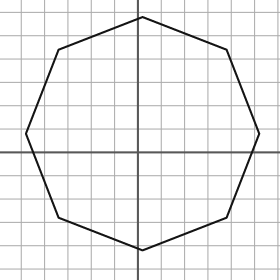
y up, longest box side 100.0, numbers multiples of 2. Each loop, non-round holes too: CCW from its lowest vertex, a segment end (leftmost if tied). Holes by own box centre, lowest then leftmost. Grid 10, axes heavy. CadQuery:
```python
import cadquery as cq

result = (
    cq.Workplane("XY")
    .moveTo(2.0, -42.0)
    .lineTo(38.0, -28.0)
    .lineTo(52.0, 8.0)
    .lineTo(38.0, 44.0)
    .lineTo(2.0, 58.0)
    .lineTo(-34.0, 44.0)
    .lineTo(-48.0, 8.0)
    .lineTo(-34.0, -28.0)
    .close()
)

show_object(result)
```